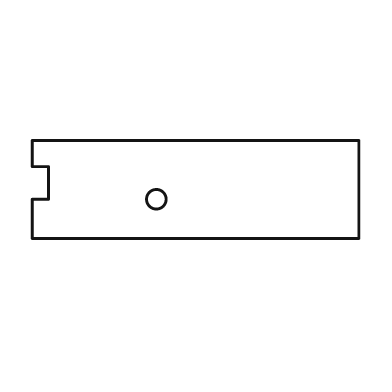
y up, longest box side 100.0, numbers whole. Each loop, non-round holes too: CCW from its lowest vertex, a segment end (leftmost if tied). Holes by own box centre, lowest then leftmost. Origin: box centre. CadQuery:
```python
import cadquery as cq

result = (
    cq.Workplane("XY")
    .moveTo(-50.0, -15.0)
    .lineTo(50.0, -15.0)
    .lineTo(50.0, 15.0)
    .lineTo(-50.0, 15.0)
    .lineTo(-50.0, 7.0)
    .lineTo(-45.0, 7.0)
    .lineTo(-45.0, -3.0)
    .lineTo(-50.0, -3.0)
    .close()
    .moveTo(-12.0, -3.0)
    .circle(3.0)
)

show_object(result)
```